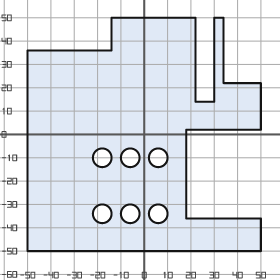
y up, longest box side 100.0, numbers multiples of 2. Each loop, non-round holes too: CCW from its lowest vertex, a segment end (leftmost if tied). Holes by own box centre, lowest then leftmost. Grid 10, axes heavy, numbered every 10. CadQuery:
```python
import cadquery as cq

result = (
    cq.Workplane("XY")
    .moveTo(-50.0, -50.0)
    .lineTo(50.0, -50.0)
    .lineTo(50.0, -36.0)
    .lineTo(18.0, -36.0)
    .lineTo(18.0, 2.0)
    .lineTo(50.0, 2.0)
    .lineTo(50.0, 22.0)
    .lineTo(34.0, 22.0)
    .lineTo(34.0, 50.0)
    .lineTo(30.0, 50.0)
    .lineTo(30.0, 14.0)
    .lineTo(22.0, 14.0)
    .lineTo(22.0, 50.0)
    .lineTo(-14.0, 50.0)
    .lineTo(-14.0, 36.0)
    .lineTo(-50.0, 36.0)
    .close()
    .moveTo(-18.0, -34.0)
    .circle(4.0)
    .moveTo(-6.0, -34.0)
    .circle(4.0)
    .moveTo(6.0, -34.0)
    .circle(4.0)
    .moveTo(-18.0, -10.0)
    .circle(4.0)
    .moveTo(-6.0, -10.0)
    .circle(4.0)
    .moveTo(6.0, -10.0)
    .circle(4.0)
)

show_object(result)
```